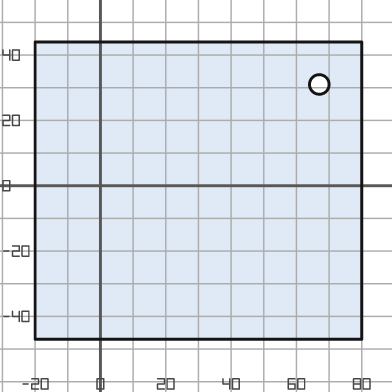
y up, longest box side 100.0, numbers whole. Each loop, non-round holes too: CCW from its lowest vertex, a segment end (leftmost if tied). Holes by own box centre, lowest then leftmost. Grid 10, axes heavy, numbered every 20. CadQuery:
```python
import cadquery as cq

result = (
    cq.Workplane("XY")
    .moveTo(-20.0, -47.0)
    .lineTo(80.0, -47.0)
    .lineTo(80.0, 44.0)
    .lineTo(-20.0, 44.0)
    .close()
    .moveTo(67.0, 31.0)
    .circle(3.0)
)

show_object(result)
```